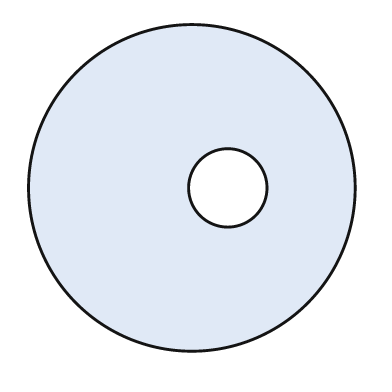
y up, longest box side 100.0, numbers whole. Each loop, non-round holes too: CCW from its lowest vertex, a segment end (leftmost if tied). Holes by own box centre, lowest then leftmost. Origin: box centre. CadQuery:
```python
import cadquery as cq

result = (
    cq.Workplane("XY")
    .moveTo(0.0, 0.0)
    .circle(50.0)
    .moveTo(11.0, 0.0)
    .circle(12.0)
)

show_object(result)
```